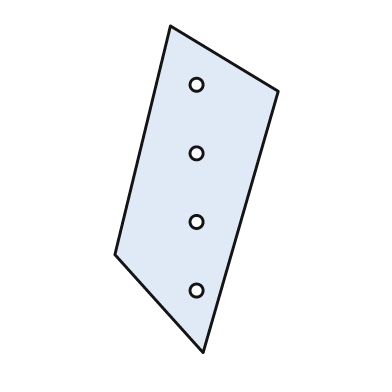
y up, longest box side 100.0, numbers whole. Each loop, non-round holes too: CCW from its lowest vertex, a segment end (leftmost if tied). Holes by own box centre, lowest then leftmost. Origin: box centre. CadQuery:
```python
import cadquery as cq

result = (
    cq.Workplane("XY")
    .moveTo(2.0, -50.0)
    .lineTo(25.0, 30.0)
    .lineTo(-8.0, 50.0)
    .lineTo(-25.0, -20.0)
    .close()
    .moveTo(0.0, -31.0)
    .circle(2.0)
    .moveTo(0.0, -10.0)
    .circle(2.0)
    .moveTo(0.0, 11.0)
    .circle(2.0)
    .moveTo(0.0, 32.0)
    .circle(2.0)
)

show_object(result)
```